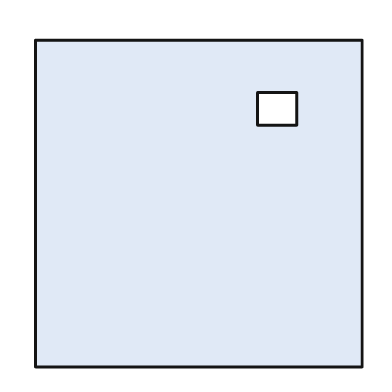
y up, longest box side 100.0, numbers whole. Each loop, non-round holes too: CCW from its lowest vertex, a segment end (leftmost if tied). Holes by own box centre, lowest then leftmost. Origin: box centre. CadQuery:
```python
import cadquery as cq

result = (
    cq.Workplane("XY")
    .moveTo(-50.0, -50.0)
    .lineTo(50.0, -50.0)
    .lineTo(50.0, 50.0)
    .lineTo(-50.0, 50.0)
    .close()
    .moveTo(18.0, 24.0)
    .lineTo(30.0, 24.0)
    .lineTo(30.0, 34.0)
    .lineTo(18.0, 34.0)
    .close()
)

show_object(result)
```